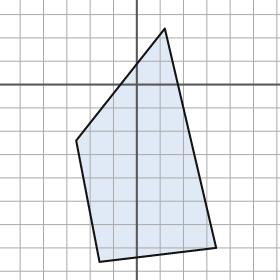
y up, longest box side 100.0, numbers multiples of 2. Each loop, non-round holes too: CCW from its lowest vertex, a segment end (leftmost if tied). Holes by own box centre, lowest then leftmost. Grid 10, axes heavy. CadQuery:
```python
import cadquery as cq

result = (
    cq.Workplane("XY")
    .moveTo(-16.0, -76.0)
    .lineTo(34.0, -70.0)
    .lineTo(12.0, 24.0)
    .lineTo(-26.0, -24.0)
    .close()
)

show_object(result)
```